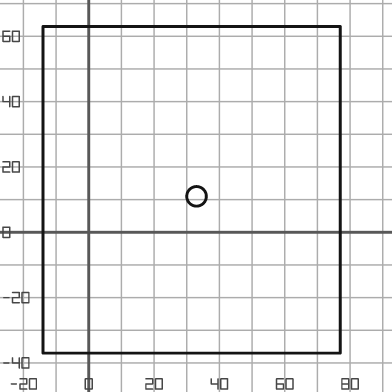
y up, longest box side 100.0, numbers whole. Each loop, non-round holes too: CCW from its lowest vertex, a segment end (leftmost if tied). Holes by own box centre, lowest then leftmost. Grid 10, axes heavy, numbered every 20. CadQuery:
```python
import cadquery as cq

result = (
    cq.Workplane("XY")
    .moveTo(-14.0, -37.0)
    .lineTo(77.0, -37.0)
    .lineTo(77.0, 63.0)
    .lineTo(-14.0, 63.0)
    .close()
    .moveTo(33.0, 11.0)
    .circle(3.0)
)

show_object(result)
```